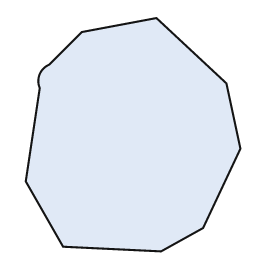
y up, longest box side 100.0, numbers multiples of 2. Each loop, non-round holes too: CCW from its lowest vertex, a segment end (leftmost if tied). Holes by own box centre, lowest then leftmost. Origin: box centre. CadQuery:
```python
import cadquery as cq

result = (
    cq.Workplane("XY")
    .moveTo(12.0, -50.0)
    .lineTo(30.0, -40.0)
    .lineTo(46.0, -6.0)
    .lineTo(40.0, 22.0)
    .lineTo(10.0, 50.0)
    .lineTo(-22.0, 44.0)
    .lineTo(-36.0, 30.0)
    .threePointArc((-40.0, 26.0), (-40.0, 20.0))
    .lineTo(-46.0, -20.0)
    .lineTo(-30.0, -48.0)
    .close()
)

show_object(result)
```